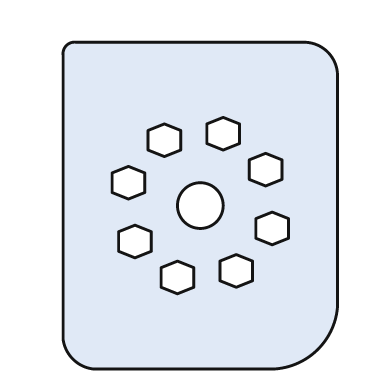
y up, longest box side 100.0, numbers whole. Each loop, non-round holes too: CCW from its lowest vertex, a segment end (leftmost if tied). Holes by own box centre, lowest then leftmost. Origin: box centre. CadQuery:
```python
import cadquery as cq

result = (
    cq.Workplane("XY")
    .moveTo(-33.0, -50.0)
    .lineTo(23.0, -50.0)
    .threePointArc((36.0, -44.0), (42.0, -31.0))
    .lineTo(42.0, 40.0)
    .threePointArc((39.0, 47.0), (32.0, 50.0))
    .lineTo(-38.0, 50.0)
    .threePointArc((-41.0, 49.0), (-42.0, 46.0))
    .lineTo(-42.0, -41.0)
    .threePointArc((-39.0, -47.0), (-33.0, -50.0))
    .close()
    .moveTo(-7.0, -27.0)
    .lineTo(-2.0, -25.0)
    .lineTo(-2.0, -19.0)
    .lineTo(-7.0, -17.0)
    .lineTo(-12.0, -19.0)
    .lineTo(-12.0, -25.0)
    .close()
    .moveTo(11.0, -25.0)
    .lineTo(16.0, -23.0)
    .lineTo(16.0, -17.0)
    .lineTo(11.0, -15.0)
    .lineTo(6.0, -17.0)
    .lineTo(6.0, -23.0)
    .close()
    .moveTo(-20.0, -16.0)
    .lineTo(-15.0, -14.0)
    .lineTo(-15.0, -8.0)
    .lineTo(-20.0, -6.0)
    .lineTo(-25.0, -8.0)
    .lineTo(-25.0, -14.0)
    .close()
    .moveTo(22.0, -12.0)
    .lineTo(27.0, -10.0)
    .lineTo(27.0, -4.0)
    .lineTo(22.0, -2.0)
    .lineTo(17.0, -4.0)
    .lineTo(17.0, -10.0)
    .close()
    .moveTo(0.0, 0.0)
    .circle(7.0)
    .moveTo(-22.0, 2.0)
    .lineTo(-17.0, 4.0)
    .lineTo(-17.0, 10.0)
    .lineTo(-22.0, 12.0)
    .lineTo(-27.0, 10.0)
    .lineTo(-27.0, 4.0)
    .close()
    .moveTo(20.0, 6.0)
    .lineTo(25.0, 8.0)
    .lineTo(25.0, 14.0)
    .lineTo(20.0, 16.0)
    .lineTo(15.0, 14.0)
    .lineTo(15.0, 8.0)
    .close()
    .moveTo(-11.0, 15.0)
    .lineTo(-6.0, 17.0)
    .lineTo(-6.0, 23.0)
    .lineTo(-11.0, 25.0)
    .lineTo(-16.0, 23.0)
    .lineTo(-16.0, 17.0)
    .close()
    .moveTo(7.0, 17.0)
    .lineTo(12.0, 19.0)
    .lineTo(12.0, 25.0)
    .lineTo(7.0, 27.0)
    .lineTo(2.0, 25.0)
    .lineTo(2.0, 19.0)
    .close()
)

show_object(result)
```